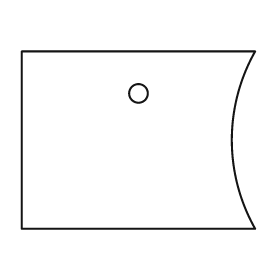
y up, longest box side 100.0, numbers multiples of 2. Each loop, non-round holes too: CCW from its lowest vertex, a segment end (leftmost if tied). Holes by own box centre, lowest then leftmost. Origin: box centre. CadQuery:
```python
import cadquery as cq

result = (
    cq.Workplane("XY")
    .moveTo(-50.0, -38.0)
    .lineTo(50.0, -38.0)
    .threePointArc((40.0, 0.0), (50.0, 38.0))
    .lineTo(-50.0, 38.0)
    .close()
    .moveTo(0.0, 20.0)
    .circle(4.0)
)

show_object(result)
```